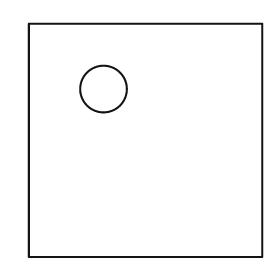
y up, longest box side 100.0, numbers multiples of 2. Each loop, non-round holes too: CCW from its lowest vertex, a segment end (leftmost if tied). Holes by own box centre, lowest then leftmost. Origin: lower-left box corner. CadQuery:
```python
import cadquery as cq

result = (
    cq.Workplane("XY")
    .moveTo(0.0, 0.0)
    .lineTo(100.0, 0.0)
    .lineTo(100.0, 100.0)
    .lineTo(0.0, 100.0)
    .close()
    .moveTo(32.0, 72.0)
    .circle(10.0)
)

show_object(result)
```